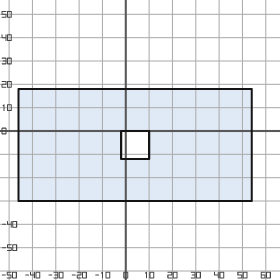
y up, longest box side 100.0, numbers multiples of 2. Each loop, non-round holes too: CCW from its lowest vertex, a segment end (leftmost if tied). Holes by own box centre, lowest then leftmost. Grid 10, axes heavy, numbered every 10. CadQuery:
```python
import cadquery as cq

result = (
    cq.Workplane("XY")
    .moveTo(-46.0, -30.0)
    .lineTo(54.0, -30.0)
    .lineTo(54.0, 18.0)
    .lineTo(-46.0, 18.0)
    .close()
    .moveTo(-2.0, -12.0)
    .lineTo(10.0, -12.0)
    .lineTo(10.0, 0.0)
    .lineTo(-2.0, 0.0)
    .close()
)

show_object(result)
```